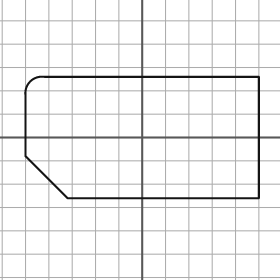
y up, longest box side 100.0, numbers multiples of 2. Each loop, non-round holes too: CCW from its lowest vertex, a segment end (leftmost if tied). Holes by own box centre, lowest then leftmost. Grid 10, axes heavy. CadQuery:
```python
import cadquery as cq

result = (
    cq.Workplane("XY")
    .moveTo(-32.0, -26.0)
    .lineTo(50.0, -26.0)
    .lineTo(50.0, 26.0)
    .lineTo(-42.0, 26.0)
    .threePointArc((-48.0, 24.0), (-50.0, 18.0))
    .lineTo(-50.0, -8.0)
    .close()
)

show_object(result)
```